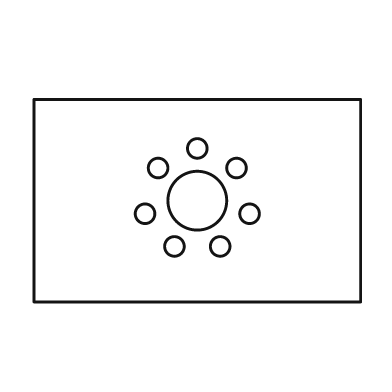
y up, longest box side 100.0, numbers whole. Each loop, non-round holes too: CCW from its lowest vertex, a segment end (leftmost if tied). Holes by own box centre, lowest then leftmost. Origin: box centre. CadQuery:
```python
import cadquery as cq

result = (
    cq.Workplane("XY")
    .moveTo(-50.0, -31.0)
    .lineTo(50.0, -31.0)
    .lineTo(50.0, 31.0)
    .lineTo(-50.0, 31.0)
    .close()
    .moveTo(-7.0, -14.0)
    .circle(3.0)
    .moveTo(7.0, -14.0)
    .circle(3.0)
    .moveTo(-16.0, -4.0)
    .circle(3.0)
    .moveTo(16.0, -4.0)
    .circle(3.0)
    .moveTo(0.0, 0.0)
    .circle(9.0)
    .moveTo(-12.0, 10.0)
    .circle(3.0)
    .moveTo(12.0, 10.0)
    .circle(3.0)
    .moveTo(0.0, 16.0)
    .circle(3.0)
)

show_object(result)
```